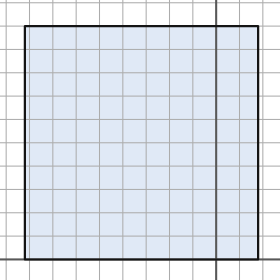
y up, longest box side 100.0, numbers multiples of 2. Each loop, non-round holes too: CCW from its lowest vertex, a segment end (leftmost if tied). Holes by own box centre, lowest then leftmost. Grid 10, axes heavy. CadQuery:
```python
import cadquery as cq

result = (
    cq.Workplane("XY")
    .moveTo(-82.0, 0.0)
    .lineTo(18.0, 0.0)
    .lineTo(18.0, 100.0)
    .lineTo(-82.0, 100.0)
    .close()
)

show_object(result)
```